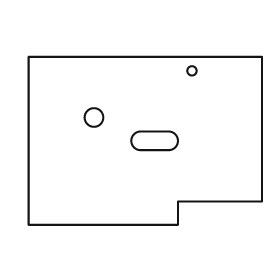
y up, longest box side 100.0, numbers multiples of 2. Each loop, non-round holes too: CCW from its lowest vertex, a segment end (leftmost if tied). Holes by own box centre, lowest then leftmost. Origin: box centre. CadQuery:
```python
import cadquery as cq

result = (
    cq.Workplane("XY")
    .moveTo(-50.0, -36.0)
    .lineTo(14.0, -36.0)
    .lineTo(14.0, -26.0)
    .lineTo(50.0, -26.0)
    .lineTo(50.0, 36.0)
    .lineTo(-50.0, 36.0)
    .close()
    .moveTo(-2.0, -4.0)
    .lineTo(10.0, -4.0)
    .threePointArc((14.0, 0.0), (10.0, 4.0))
    .lineTo(-2.0, 4.0)
    .threePointArc((-6.0, 0.0), (-2.0, -4.0))
    .close()
    .moveTo(-22.0, 10.0)
    .circle(4.0)
    .moveTo(20.0, 30.0)
    .circle(2.0)
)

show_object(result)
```